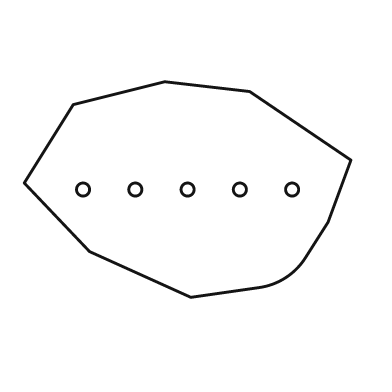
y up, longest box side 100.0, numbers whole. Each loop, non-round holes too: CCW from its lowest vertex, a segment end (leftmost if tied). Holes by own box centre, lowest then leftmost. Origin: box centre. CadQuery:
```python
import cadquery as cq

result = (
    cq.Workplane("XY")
    .moveTo(1.0, -33.0)
    .lineTo(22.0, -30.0)
    .threePointArc((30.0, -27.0), (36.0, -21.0))
    .lineTo(43.0, -10.0)
    .lineTo(50.0, 9.0)
    .lineTo(19.0, 30.0)
    .lineTo(-7.0, 33.0)
    .lineTo(-35.0, 26.0)
    .lineTo(-50.0, 2.0)
    .lineTo(-30.0, -19.0)
    .close()
    .moveTo(-32.0, 0.0)
    .circle(2.0)
    .moveTo(-16.0, 0.0)
    .circle(2.0)
    .moveTo(0.0, 0.0)
    .circle(2.0)
    .moveTo(16.0, 0.0)
    .circle(2.0)
    .moveTo(32.0, 0.0)
    .circle(2.0)
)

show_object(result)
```